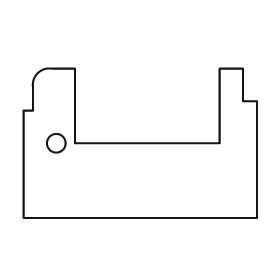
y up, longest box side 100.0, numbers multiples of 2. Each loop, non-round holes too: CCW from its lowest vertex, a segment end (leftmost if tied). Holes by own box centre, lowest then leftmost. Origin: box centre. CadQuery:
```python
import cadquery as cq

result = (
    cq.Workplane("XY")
    .moveTo(-50.0, -32.0)
    .lineTo(50.0, -32.0)
    .lineTo(50.0, 18.0)
    .lineTo(44.0, 18.0)
    .lineTo(44.0, 32.0)
    .lineTo(34.0, 32.0)
    .lineTo(34.0, 0.0)
    .lineTo(-28.0, 0.0)
    .lineTo(-28.0, 32.0)
    .lineTo(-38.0, 32.0)
    .threePointArc((-44.0, 30.0), (-46.0, 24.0))
    .lineTo(-46.0, 14.0)
    .lineTo(-50.0, 14.0)
    .close()
    .moveTo(-36.0, 0.0)
    .circle(4.0)
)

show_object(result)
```